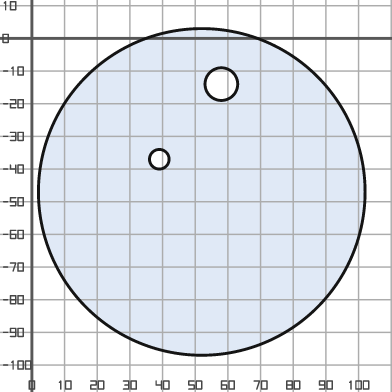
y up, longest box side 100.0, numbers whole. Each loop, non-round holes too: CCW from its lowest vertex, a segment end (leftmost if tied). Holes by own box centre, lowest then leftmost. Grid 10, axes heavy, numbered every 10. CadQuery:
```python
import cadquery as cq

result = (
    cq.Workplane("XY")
    .moveTo(52.0, -47.0)
    .circle(50.0)
    .moveTo(39.0, -37.0)
    .circle(3.0)
    .moveTo(58.0, -14.0)
    .circle(5.0)
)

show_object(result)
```